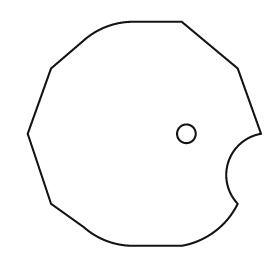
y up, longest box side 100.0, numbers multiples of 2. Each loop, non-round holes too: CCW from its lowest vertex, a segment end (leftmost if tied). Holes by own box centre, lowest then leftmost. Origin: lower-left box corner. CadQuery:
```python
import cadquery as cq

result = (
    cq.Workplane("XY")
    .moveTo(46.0, 0.0)
    .lineTo(66.0, 0.0)
    .threePointArc((80.0, 6.0), (90.0, 18.0))
    .threePointArc((86.0, 36.0), (100.0, 48.0))
    .lineTo(90.0, 76.0)
    .lineTo(66.0, 96.0)
    .lineTo(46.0, 96.0)
    .threePointArc((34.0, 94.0), (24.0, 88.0))
    .lineTo(10.0, 76.0)
    .lineTo(0.0, 48.0)
    .lineTo(10.0, 18.0)
    .lineTo(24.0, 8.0)
    .threePointArc((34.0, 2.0), (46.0, 0.0))
    .close()
    .moveTo(68.0, 48.0)
    .circle(4.0)
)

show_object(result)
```